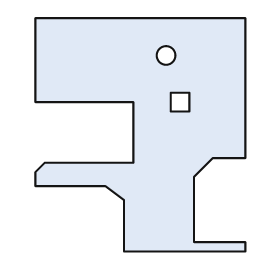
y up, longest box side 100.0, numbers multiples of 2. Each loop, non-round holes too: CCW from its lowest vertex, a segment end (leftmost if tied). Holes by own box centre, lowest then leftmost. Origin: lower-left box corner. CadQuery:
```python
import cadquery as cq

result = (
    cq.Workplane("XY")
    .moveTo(38.0, 0.0)
    .lineTo(90.0, 0.0)
    .lineTo(90.0, 4.0)
    .lineTo(68.0, 4.0)
    .lineTo(68.0, 32.0)
    .lineTo(76.0, 40.0)
    .lineTo(90.0, 40.0)
    .lineTo(90.0, 100.0)
    .lineTo(0.0, 100.0)
    .lineTo(0.0, 64.0)
    .lineTo(42.0, 64.0)
    .lineTo(42.0, 38.0)
    .lineTo(4.0, 38.0)
    .lineTo(0.0, 34.0)
    .lineTo(0.0, 28.0)
    .lineTo(30.0, 28.0)
    .lineTo(38.0, 22.0)
    .close()
    .moveTo(58.0, 60.0)
    .lineTo(66.0, 60.0)
    .lineTo(66.0, 68.0)
    .lineTo(58.0, 68.0)
    .close()
    .moveTo(56.0, 84.0)
    .circle(4.0)
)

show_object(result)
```